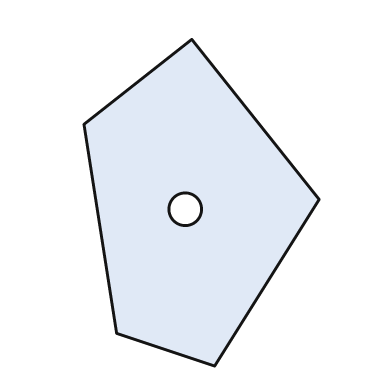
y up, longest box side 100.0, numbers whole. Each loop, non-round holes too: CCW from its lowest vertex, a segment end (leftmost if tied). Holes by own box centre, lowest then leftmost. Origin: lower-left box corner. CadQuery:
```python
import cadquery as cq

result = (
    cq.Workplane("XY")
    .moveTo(40.0, 0.0)
    .lineTo(72.0, 51.0)
    .lineTo(33.0, 100.0)
    .lineTo(0.0, 74.0)
    .lineTo(10.0, 10.0)
    .close()
    .moveTo(31.0, 48.0)
    .circle(5.0)
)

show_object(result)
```